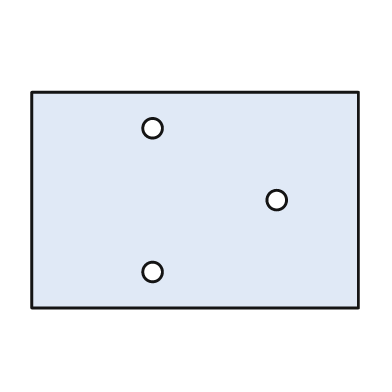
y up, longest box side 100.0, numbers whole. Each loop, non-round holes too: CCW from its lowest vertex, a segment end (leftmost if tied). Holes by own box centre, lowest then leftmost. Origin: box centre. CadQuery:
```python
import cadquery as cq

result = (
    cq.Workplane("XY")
    .moveTo(-50.0, -33.0)
    .lineTo(50.0, -33.0)
    .lineTo(50.0, 33.0)
    .lineTo(-50.0, 33.0)
    .close()
    .moveTo(-13.0, -22.0)
    .circle(3.0)
    .moveTo(25.0, 0.0)
    .circle(3.0)
    .moveTo(-13.0, 22.0)
    .circle(3.0)
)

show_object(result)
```